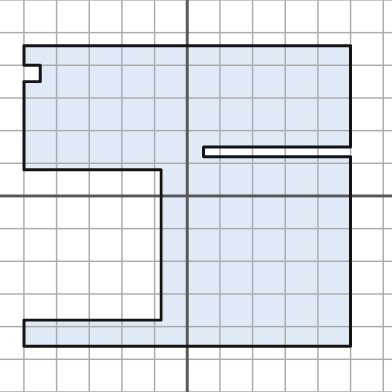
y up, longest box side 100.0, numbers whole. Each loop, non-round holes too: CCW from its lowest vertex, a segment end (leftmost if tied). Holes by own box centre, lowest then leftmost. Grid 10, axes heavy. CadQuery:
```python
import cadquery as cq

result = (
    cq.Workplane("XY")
    .moveTo(-50.0, -46.0)
    .lineTo(50.0, -46.0)
    .lineTo(50.0, 12.0)
    .lineTo(5.0, 12.0)
    .lineTo(5.0, 15.0)
    .lineTo(50.0, 15.0)
    .lineTo(50.0, 46.0)
    .lineTo(-50.0, 46.0)
    .lineTo(-50.0, 40.0)
    .lineTo(-45.0, 40.0)
    .lineTo(-45.0, 35.0)
    .lineTo(-50.0, 35.0)
    .lineTo(-50.0, 8.0)
    .lineTo(-8.0, 8.0)
    .lineTo(-8.0, -38.0)
    .lineTo(-50.0, -38.0)
    .close()
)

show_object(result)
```